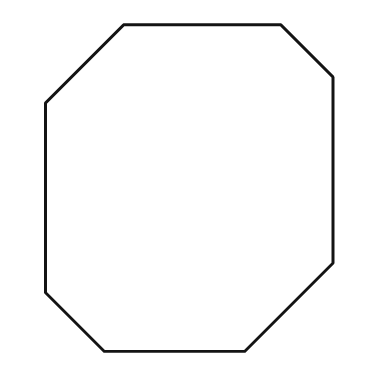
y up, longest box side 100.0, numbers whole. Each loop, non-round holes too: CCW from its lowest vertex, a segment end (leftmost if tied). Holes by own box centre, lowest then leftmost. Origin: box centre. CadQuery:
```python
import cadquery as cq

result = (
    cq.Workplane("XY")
    .moveTo(-26.0, -50.0)
    .lineTo(17.0, -50.0)
    .lineTo(44.0, -23.0)
    .lineTo(44.0, 34.0)
    .lineTo(28.0, 50.0)
    .lineTo(-20.0, 50.0)
    .lineTo(-44.0, 26.0)
    .lineTo(-44.0, -32.0)
    .close()
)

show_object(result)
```